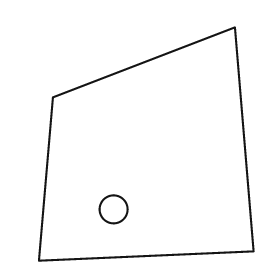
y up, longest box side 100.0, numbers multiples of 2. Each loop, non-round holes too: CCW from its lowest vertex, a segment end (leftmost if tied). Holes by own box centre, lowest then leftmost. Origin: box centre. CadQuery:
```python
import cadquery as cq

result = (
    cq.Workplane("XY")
    .moveTo(-46.0, -50.0)
    .lineTo(46.0, -46.0)
    .lineTo(38.0, 50.0)
    .lineTo(-40.0, 20.0)
    .close()
    .moveTo(-14.0, -28.0)
    .circle(6.0)
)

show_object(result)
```